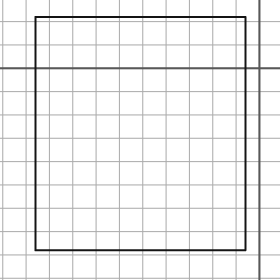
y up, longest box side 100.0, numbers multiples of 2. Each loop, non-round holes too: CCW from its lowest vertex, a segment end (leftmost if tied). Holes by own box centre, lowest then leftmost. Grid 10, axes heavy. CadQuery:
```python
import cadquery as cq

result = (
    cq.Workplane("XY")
    .moveTo(-96.0, -78.0)
    .lineTo(-6.0, -78.0)
    .lineTo(-6.0, 22.0)
    .lineTo(-96.0, 22.0)
    .close()
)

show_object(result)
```